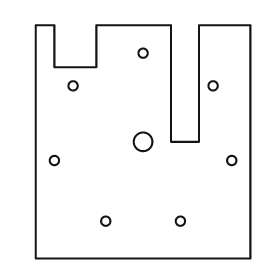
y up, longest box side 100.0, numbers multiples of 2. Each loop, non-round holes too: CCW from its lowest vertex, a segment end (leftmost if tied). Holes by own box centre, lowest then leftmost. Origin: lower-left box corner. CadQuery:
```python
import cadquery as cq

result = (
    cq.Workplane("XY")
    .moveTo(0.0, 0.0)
    .lineTo(92.0, 0.0)
    .lineTo(92.0, 100.0)
    .lineTo(70.0, 100.0)
    .lineTo(70.0, 50.0)
    .lineTo(58.0, 50.0)
    .lineTo(58.0, 100.0)
    .lineTo(26.0, 100.0)
    .lineTo(26.0, 82.0)
    .lineTo(8.0, 82.0)
    .lineTo(8.0, 100.0)
    .lineTo(0.0, 100.0)
    .close()
    .moveTo(30.0, 16.0)
    .circle(2.0)
    .moveTo(62.0, 16.0)
    .circle(2.0)
    .moveTo(8.0, 42.0)
    .circle(2.0)
    .moveTo(84.0, 42.0)
    .circle(2.0)
    .moveTo(46.0, 50.0)
    .circle(4.0)
    .moveTo(16.0, 74.0)
    .circle(2.0)
    .moveTo(76.0, 74.0)
    .circle(2.0)
    .moveTo(46.0, 88.0)
    .circle(2.0)
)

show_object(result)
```